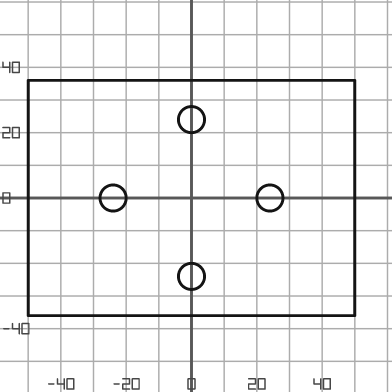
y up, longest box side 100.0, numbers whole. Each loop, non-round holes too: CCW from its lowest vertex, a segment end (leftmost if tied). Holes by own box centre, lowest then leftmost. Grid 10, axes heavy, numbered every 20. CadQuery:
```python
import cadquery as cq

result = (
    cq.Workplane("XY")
    .moveTo(-50.0, -36.0)
    .lineTo(50.0, -36.0)
    .lineTo(50.0, 36.0)
    .lineTo(-50.0, 36.0)
    .close()
    .moveTo(0.0, -24.0)
    .circle(4.0)
    .moveTo(-24.0, 0.0)
    .circle(4.0)
    .moveTo(24.0, 0.0)
    .circle(4.0)
    .moveTo(0.0, 24.0)
    .circle(4.0)
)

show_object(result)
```